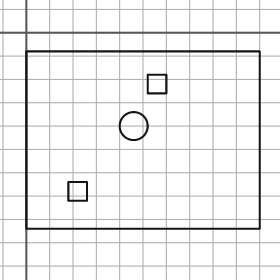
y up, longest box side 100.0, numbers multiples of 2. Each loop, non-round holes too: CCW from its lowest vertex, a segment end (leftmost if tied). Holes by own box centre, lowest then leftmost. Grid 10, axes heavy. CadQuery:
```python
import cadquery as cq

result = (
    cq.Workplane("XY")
    .moveTo(0.0, -84.0)
    .lineTo(100.0, -84.0)
    .lineTo(100.0, -8.0)
    .lineTo(0.0, -8.0)
    .close()
    .moveTo(18.0, -72.0)
    .lineTo(26.0, -72.0)
    .lineTo(26.0, -64.0)
    .lineTo(18.0, -64.0)
    .close()
    .moveTo(46.0, -40.0)
    .circle(6.0)
    .moveTo(52.0, -26.0)
    .lineTo(60.0, -26.0)
    .lineTo(60.0, -18.0)
    .lineTo(52.0, -18.0)
    .close()
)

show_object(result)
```